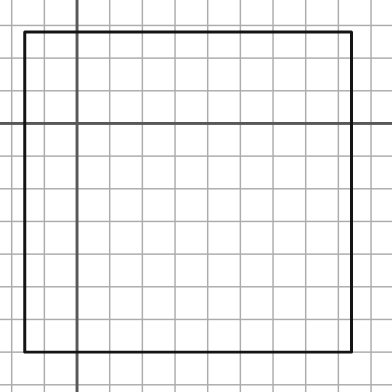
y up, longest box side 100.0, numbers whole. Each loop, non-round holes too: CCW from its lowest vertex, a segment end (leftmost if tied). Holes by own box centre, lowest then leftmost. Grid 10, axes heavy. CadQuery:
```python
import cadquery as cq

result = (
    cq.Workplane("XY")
    .moveTo(-16.0, -70.0)
    .lineTo(84.0, -70.0)
    .lineTo(84.0, 28.0)
    .lineTo(-16.0, 28.0)
    .close()
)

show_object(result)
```